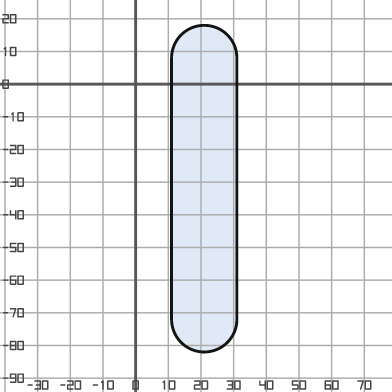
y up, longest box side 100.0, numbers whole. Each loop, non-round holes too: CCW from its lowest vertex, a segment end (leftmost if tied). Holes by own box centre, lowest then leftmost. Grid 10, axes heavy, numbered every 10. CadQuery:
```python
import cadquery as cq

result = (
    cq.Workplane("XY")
    .moveTo(11.0, -72.0)
    .threePointArc((21.0, -82.0), (31.0, -72.0))
    .lineTo(31.0, 8.0)
    .threePointArc((21.0, 18.0), (11.0, 8.0))
    .close()
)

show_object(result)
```